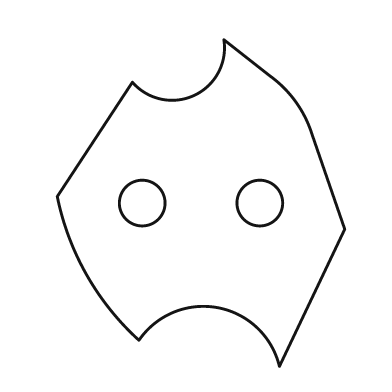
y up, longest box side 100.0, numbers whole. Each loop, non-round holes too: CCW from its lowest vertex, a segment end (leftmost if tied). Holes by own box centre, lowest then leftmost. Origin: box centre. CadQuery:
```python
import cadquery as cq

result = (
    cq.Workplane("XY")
    .moveTo(24.0, -50.0)
    .lineTo(44.0, -8.0)
    .lineTo(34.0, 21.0)
    .threePointArc((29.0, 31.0), (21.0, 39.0))
    .lineTo(7.0, 50.0)
    .threePointArc((-2.0, 33.0), (-21.0, 37.0))
    .lineTo(-44.0, 2.0)
    .threePointArc((-35.0, -22.0), (-19.0, -42.0))
    .threePointArc((5.0, -32.0), (24.0, -50.0))
    .close()
    .moveTo(-18.0, 0.0)
    .circle(7.0)
    .moveTo(18.0, 0.0)
    .circle(7.0)
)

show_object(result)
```